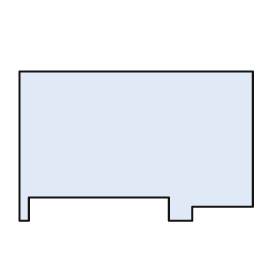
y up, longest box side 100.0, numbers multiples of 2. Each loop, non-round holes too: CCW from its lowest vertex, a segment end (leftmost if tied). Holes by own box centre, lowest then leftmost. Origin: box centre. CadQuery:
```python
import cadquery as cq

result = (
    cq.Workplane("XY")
    .moveTo(-50.0, -32.0)
    .lineTo(-46.0, -32.0)
    .lineTo(-46.0, -22.0)
    .lineTo(14.0, -22.0)
    .lineTo(14.0, -32.0)
    .lineTo(24.0, -32.0)
    .lineTo(24.0, -26.0)
    .lineTo(50.0, -26.0)
    .lineTo(50.0, 32.0)
    .lineTo(-50.0, 32.0)
    .close()
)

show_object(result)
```